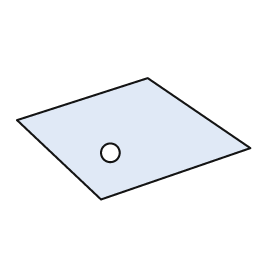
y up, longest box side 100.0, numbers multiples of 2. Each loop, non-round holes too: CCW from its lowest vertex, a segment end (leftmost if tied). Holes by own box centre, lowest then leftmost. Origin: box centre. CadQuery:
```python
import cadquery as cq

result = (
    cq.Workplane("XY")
    .moveTo(-14.0, -26.0)
    .lineTo(50.0, -4.0)
    .lineTo(6.0, 26.0)
    .lineTo(-50.0, 8.0)
    .close()
    .moveTo(-10.0, -6.0)
    .circle(4.0)
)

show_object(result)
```